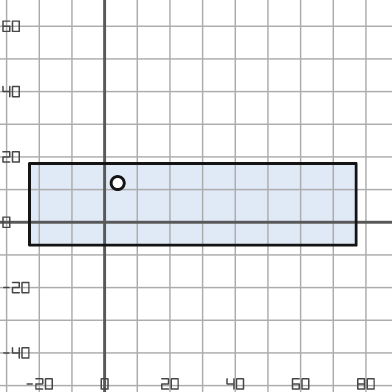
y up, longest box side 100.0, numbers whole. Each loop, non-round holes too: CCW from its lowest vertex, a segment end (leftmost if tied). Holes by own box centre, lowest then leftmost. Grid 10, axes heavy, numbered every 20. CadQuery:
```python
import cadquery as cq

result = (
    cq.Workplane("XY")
    .moveTo(-23.0, -7.0)
    .lineTo(77.0, -7.0)
    .lineTo(77.0, 18.0)
    .lineTo(-23.0, 18.0)
    .close()
    .moveTo(4.0, 12.0)
    .circle(2.0)
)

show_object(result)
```